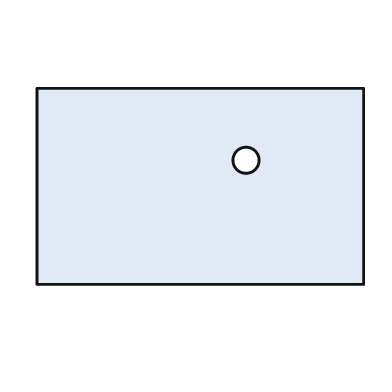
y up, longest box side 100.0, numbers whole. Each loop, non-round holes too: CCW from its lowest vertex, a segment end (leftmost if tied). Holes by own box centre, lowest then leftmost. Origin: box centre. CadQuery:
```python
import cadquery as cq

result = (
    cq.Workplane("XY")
    .moveTo(-50.0, -30.0)
    .lineTo(50.0, -30.0)
    .lineTo(50.0, 30.0)
    .lineTo(-50.0, 30.0)
    .close()
    .moveTo(14.0, 8.0)
    .circle(4.0)
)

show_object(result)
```